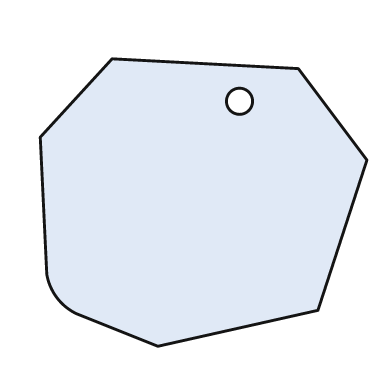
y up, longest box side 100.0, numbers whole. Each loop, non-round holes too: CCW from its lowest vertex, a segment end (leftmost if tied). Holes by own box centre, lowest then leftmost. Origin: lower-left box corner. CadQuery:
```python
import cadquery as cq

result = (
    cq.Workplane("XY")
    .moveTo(36.0, 0.0)
    .lineTo(85.0, 11.0)
    .lineTo(100.0, 57.0)
    .lineTo(79.0, 85.0)
    .lineTo(22.0, 88.0)
    .lineTo(0.0, 64.0)
    .lineTo(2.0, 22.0)
    .threePointArc((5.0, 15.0), (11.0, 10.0))
    .close()
    .moveTo(61.0, 75.0)
    .circle(4.0)
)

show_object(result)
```